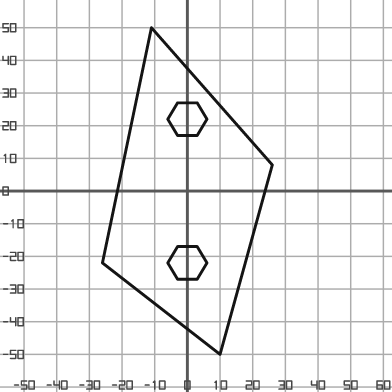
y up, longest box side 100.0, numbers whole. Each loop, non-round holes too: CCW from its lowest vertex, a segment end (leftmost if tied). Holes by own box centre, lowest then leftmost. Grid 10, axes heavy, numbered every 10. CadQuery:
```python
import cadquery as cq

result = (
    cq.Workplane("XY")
    .moveTo(10.0, -50.0)
    .lineTo(26.0, 8.0)
    .lineTo(-11.0, 50.0)
    .lineTo(-26.0, -22.0)
    .close()
    .moveTo(-3.0, -27.0)
    .lineTo(3.0, -27.0)
    .lineTo(6.0, -22.0)
    .lineTo(3.0, -17.0)
    .lineTo(-3.0, -17.0)
    .lineTo(-6.0, -22.0)
    .close()
    .moveTo(-3.0, 17.0)
    .lineTo(3.0, 17.0)
    .lineTo(6.0, 22.0)
    .lineTo(3.0, 27.0)
    .lineTo(-3.0, 27.0)
    .lineTo(-6.0, 22.0)
    .close()
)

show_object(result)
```